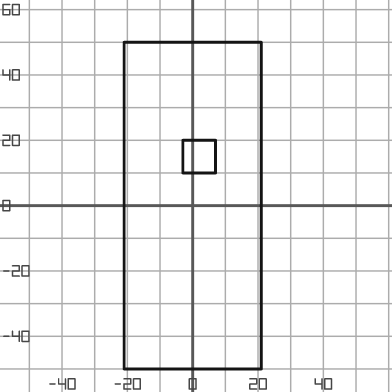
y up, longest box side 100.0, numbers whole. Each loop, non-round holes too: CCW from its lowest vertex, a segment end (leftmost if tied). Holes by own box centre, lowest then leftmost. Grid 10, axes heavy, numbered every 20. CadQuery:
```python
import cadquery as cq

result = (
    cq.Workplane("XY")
    .moveTo(-21.0, -50.0)
    .lineTo(21.0, -50.0)
    .lineTo(21.0, 50.0)
    .lineTo(-21.0, 50.0)
    .close()
    .moveTo(-3.0, 10.0)
    .lineTo(7.0, 10.0)
    .lineTo(7.0, 20.0)
    .lineTo(-3.0, 20.0)
    .close()
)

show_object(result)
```